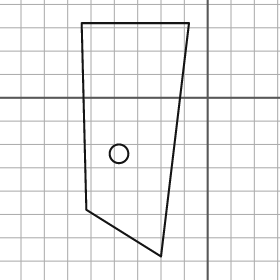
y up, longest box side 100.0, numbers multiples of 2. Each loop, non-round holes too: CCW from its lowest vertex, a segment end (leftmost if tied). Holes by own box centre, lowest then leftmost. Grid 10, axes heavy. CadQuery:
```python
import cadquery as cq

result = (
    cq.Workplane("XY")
    .moveTo(-20.0, -68.0)
    .lineTo(-8.0, 32.0)
    .lineTo(-54.0, 32.0)
    .lineTo(-52.0, -48.0)
    .close()
    .moveTo(-38.0, -24.0)
    .circle(4.0)
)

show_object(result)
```